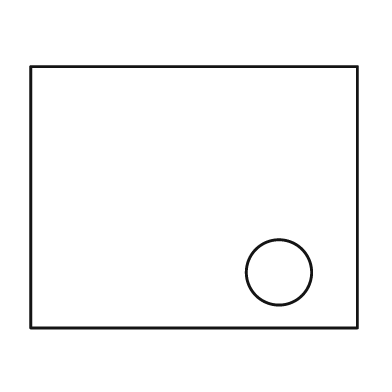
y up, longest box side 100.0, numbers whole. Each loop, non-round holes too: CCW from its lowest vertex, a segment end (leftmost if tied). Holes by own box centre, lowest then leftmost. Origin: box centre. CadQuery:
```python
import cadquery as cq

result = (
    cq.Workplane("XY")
    .moveTo(-50.0, -40.0)
    .lineTo(50.0, -40.0)
    .lineTo(50.0, 40.0)
    .lineTo(-50.0, 40.0)
    .close()
    .moveTo(26.0, -23.0)
    .circle(10.0)
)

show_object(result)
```